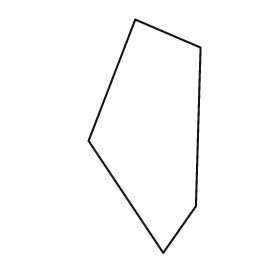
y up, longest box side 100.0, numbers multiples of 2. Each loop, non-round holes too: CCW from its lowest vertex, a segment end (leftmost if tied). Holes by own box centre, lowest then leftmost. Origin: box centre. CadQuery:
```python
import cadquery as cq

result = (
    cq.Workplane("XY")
    .moveTo(8.0, -50.0)
    .lineTo(22.0, -30.0)
    .lineTo(24.0, 38.0)
    .lineTo(-4.0, 50.0)
    .lineTo(-24.0, -2.0)
    .close()
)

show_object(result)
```